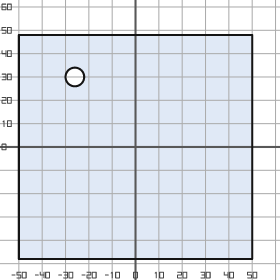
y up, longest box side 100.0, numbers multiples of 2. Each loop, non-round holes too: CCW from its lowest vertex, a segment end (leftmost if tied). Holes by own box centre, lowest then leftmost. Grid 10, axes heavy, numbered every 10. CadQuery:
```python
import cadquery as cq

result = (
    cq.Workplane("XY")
    .moveTo(-50.0, -48.0)
    .lineTo(50.0, -48.0)
    .lineTo(50.0, 48.0)
    .lineTo(-50.0, 48.0)
    .close()
    .moveTo(-26.0, 30.0)
    .circle(4.0)
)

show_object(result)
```